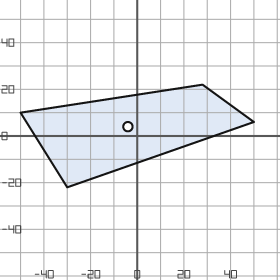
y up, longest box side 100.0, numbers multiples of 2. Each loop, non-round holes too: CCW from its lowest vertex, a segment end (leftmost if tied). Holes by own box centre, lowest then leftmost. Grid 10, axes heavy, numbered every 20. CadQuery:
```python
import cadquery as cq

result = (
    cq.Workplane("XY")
    .moveTo(-30.0, -22.0)
    .lineTo(50.0, 6.0)
    .lineTo(28.0, 22.0)
    .lineTo(-50.0, 10.0)
    .close()
    .moveTo(-4.0, 4.0)
    .circle(2.0)
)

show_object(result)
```